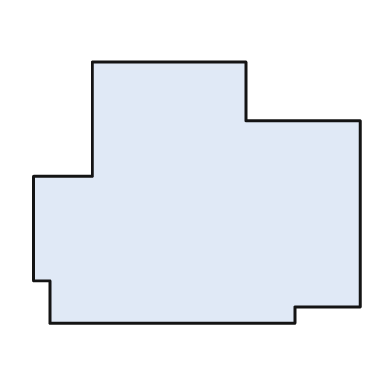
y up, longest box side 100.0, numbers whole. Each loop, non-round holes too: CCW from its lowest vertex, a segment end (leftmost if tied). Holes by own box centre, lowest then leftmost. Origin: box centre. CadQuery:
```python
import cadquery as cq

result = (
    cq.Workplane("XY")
    .moveTo(-45.0, -40.0)
    .lineTo(30.0, -40.0)
    .lineTo(30.0, -35.0)
    .lineTo(50.0, -35.0)
    .lineTo(50.0, 22.0)
    .lineTo(15.0, 22.0)
    .lineTo(15.0, 40.0)
    .lineTo(-32.0, 40.0)
    .lineTo(-32.0, 5.0)
    .lineTo(-50.0, 5.0)
    .lineTo(-50.0, -27.0)
    .lineTo(-45.0, -27.0)
    .close()
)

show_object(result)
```